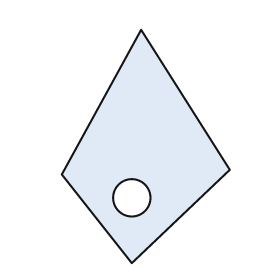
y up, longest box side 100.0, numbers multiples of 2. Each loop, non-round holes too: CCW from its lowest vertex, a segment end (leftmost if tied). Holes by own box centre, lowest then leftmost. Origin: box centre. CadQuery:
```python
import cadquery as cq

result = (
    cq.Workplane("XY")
    .moveTo(-6.0, -50.0)
    .lineTo(36.0, -10.0)
    .lineTo(-2.0, 50.0)
    .lineTo(-36.0, -12.0)
    .close()
    .moveTo(-6.0, -22.0)
    .circle(8.0)
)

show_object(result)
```